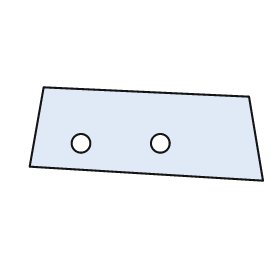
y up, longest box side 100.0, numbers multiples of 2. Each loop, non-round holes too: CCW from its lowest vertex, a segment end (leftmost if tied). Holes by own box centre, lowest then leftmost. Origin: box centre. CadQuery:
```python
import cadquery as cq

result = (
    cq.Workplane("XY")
    .moveTo(50.0, -20.0)
    .lineTo(44.0, 16.0)
    .lineTo(-44.0, 20.0)
    .lineTo(-50.0, -14.0)
    .close()
    .moveTo(-28.0, -4.0)
    .circle(4.0)
    .moveTo(6.0, -4.0)
    .circle(4.0)
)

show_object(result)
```